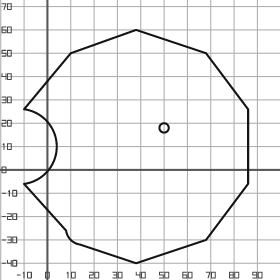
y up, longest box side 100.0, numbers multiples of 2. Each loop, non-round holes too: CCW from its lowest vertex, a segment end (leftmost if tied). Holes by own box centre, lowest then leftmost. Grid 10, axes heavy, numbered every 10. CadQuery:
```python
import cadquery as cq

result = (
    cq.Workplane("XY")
    .moveTo(38.0, -40.0)
    .lineTo(68.0, -30.0)
    .lineTo(86.0, -6.0)
    .lineTo(86.0, 26.0)
    .lineTo(68.0, 50.0)
    .lineTo(38.0, 60.0)
    .lineTo(10.0, 50.0)
    .lineTo(-10.0, 26.0)
    .threePointArc((4.0, 10.0), (-10.0, -6.0))
    .lineTo(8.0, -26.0)
    .threePointArc((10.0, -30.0), (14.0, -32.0))
    .close()
    .moveTo(50.0, 18.0)
    .circle(2.0)
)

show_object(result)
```